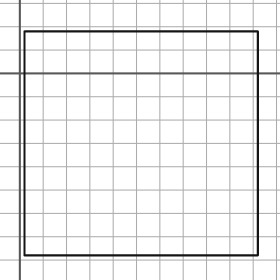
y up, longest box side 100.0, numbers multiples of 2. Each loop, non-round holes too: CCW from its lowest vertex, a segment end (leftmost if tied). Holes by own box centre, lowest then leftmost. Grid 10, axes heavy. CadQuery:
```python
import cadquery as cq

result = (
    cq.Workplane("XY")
    .moveTo(2.0, -78.0)
    .lineTo(102.0, -78.0)
    .lineTo(102.0, 18.0)
    .lineTo(2.0, 18.0)
    .close()
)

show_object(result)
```